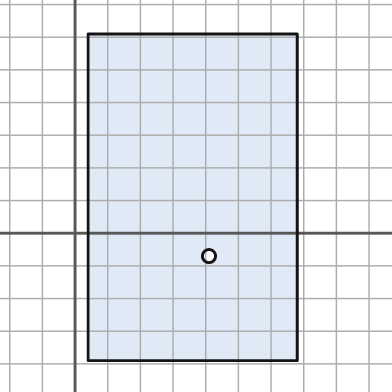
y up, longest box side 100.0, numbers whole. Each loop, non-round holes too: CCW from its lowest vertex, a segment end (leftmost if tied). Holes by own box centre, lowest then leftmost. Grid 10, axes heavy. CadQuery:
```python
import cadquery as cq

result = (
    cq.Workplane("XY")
    .moveTo(4.0, -39.0)
    .lineTo(68.0, -39.0)
    .lineTo(68.0, 61.0)
    .lineTo(4.0, 61.0)
    .close()
    .moveTo(41.0, -7.0)
    .circle(2.0)
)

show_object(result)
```